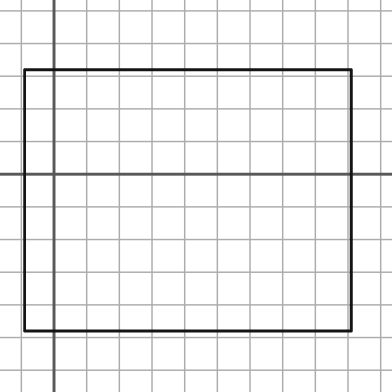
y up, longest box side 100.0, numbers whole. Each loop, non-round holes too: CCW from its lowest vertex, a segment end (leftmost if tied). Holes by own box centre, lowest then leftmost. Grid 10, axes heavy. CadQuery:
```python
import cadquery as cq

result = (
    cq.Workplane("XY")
    .moveTo(-9.0, -48.0)
    .lineTo(91.0, -48.0)
    .lineTo(91.0, 32.0)
    .lineTo(-9.0, 32.0)
    .close()
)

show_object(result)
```